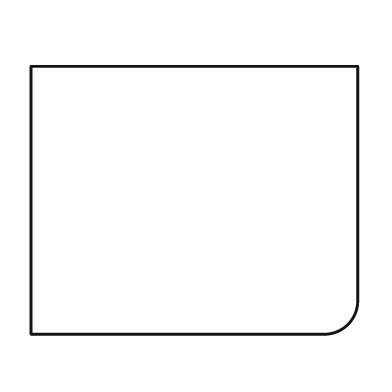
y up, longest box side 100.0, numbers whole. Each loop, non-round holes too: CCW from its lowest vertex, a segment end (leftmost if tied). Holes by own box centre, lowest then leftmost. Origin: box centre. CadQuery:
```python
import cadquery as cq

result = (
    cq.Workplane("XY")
    .moveTo(-50.0, -41.0)
    .lineTo(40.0, -41.0)
    .threePointArc((47.0, -38.0), (50.0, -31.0))
    .lineTo(50.0, 41.0)
    .lineTo(-50.0, 41.0)
    .close()
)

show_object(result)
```